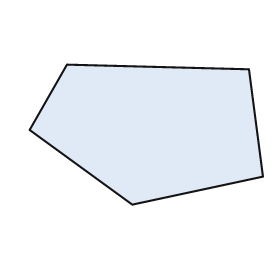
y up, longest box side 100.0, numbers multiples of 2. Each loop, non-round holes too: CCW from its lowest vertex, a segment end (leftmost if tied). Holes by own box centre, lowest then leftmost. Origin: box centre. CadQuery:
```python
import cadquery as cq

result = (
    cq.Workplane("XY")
    .moveTo(-6.0, -30.0)
    .lineTo(50.0, -18.0)
    .lineTo(44.0, 28.0)
    .lineTo(-34.0, 30.0)
    .lineTo(-50.0, 2.0)
    .close()
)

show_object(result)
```